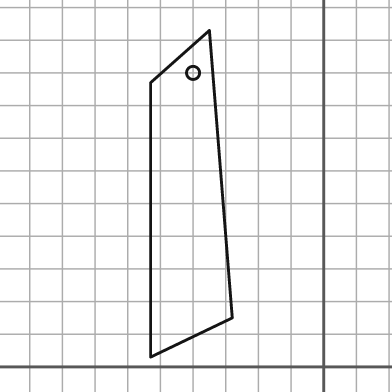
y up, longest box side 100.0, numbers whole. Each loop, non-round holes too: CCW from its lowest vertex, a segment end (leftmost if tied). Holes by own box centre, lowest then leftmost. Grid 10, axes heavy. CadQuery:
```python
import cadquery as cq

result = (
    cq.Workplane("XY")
    .moveTo(-53.0, 3.0)
    .lineTo(-28.0, 15.0)
    .lineTo(-35.0, 103.0)
    .lineTo(-53.0, 87.0)
    .close()
    .moveTo(-40.0, 90.0)
    .circle(2.0)
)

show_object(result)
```